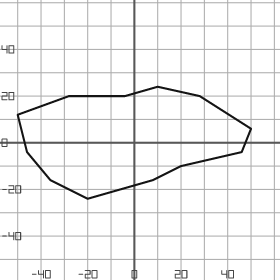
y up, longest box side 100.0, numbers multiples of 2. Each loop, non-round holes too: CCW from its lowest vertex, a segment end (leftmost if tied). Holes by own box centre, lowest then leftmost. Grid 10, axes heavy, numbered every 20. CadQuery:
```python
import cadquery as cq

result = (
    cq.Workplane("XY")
    .moveTo(-20.0, -24.0)
    .lineTo(8.0, -16.0)
    .lineTo(20.0, -10.0)
    .lineTo(46.0, -4.0)
    .lineTo(50.0, 6.0)
    .lineTo(28.0, 20.0)
    .lineTo(10.0, 24.0)
    .lineTo(-4.0, 20.0)
    .lineTo(-28.0, 20.0)
    .lineTo(-50.0, 12.0)
    .lineTo(-46.0, -4.0)
    .lineTo(-36.0, -16.0)
    .close()
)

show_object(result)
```